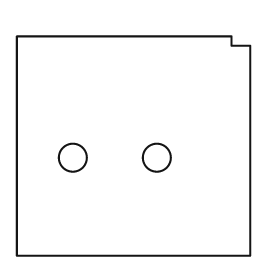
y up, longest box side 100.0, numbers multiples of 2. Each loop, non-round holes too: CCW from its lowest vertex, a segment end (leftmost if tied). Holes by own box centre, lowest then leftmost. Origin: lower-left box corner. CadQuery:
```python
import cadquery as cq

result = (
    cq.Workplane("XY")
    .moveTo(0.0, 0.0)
    .lineTo(100.0, 0.0)
    .lineTo(100.0, 90.0)
    .lineTo(92.0, 90.0)
    .lineTo(92.0, 94.0)
    .lineTo(0.0, 94.0)
    .close()
    .moveTo(24.0, 42.0)
    .circle(6.0)
    .moveTo(60.0, 42.0)
    .circle(6.0)
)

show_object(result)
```